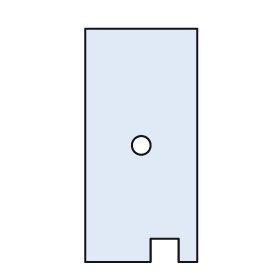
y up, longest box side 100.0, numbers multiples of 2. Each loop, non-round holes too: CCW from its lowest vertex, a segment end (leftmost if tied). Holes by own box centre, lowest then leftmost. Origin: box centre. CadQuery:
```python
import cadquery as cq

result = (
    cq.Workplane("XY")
    .moveTo(-24.0, -50.0)
    .lineTo(4.0, -50.0)
    .lineTo(4.0, -40.0)
    .lineTo(16.0, -40.0)
    .lineTo(16.0, -50.0)
    .lineTo(24.0, -50.0)
    .lineTo(24.0, 50.0)
    .lineTo(-24.0, 50.0)
    .close()
    .moveTo(0.0, 0.0)
    .circle(4.0)
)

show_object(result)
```